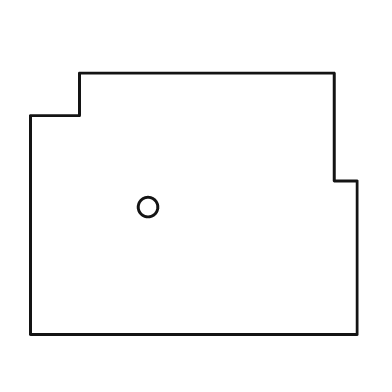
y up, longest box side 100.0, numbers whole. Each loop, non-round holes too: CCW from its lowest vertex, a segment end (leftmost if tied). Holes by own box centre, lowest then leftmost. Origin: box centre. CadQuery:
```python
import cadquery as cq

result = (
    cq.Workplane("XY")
    .moveTo(-50.0, -40.0)
    .lineTo(50.0, -40.0)
    .lineTo(50.0, 7.0)
    .lineTo(43.0, 7.0)
    .lineTo(43.0, 40.0)
    .lineTo(-35.0, 40.0)
    .lineTo(-35.0, 27.0)
    .lineTo(-50.0, 27.0)
    .close()
    .moveTo(-14.0, -1.0)
    .circle(3.0)
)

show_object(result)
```